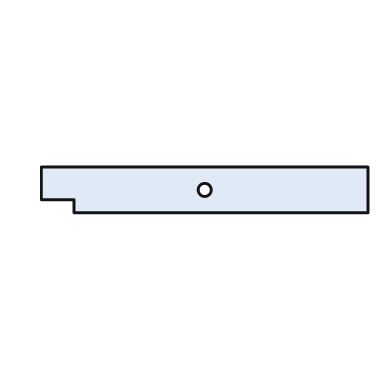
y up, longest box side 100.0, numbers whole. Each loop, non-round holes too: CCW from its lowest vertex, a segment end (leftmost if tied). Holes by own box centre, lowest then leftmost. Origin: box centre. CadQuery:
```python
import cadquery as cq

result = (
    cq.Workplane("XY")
    .moveTo(-40.0, -7.0)
    .lineTo(50.0, -7.0)
    .lineTo(50.0, 7.0)
    .lineTo(-50.0, 7.0)
    .lineTo(-50.0, -3.0)
    .lineTo(-40.0, -3.0)
    .close()
    .moveTo(0.0, 0.0)
    .circle(2.0)
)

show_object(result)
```